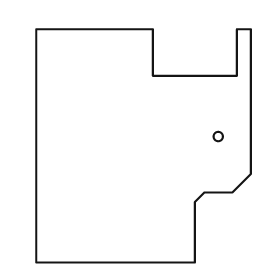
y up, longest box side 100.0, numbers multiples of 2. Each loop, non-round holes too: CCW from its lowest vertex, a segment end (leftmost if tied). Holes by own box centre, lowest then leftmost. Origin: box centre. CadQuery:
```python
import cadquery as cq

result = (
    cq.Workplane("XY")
    .moveTo(-46.0, -50.0)
    .lineTo(22.0, -50.0)
    .lineTo(22.0, -24.0)
    .lineTo(26.0, -20.0)
    .lineTo(38.0, -20.0)
    .lineTo(46.0, -12.0)
    .lineTo(46.0, 50.0)
    .lineTo(40.0, 50.0)
    .lineTo(40.0, 30.0)
    .lineTo(4.0, 30.0)
    .lineTo(4.0, 50.0)
    .lineTo(-46.0, 50.0)
    .close()
    .moveTo(32.0, 4.0)
    .circle(2.0)
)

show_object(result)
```